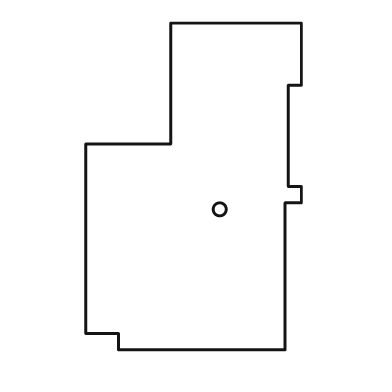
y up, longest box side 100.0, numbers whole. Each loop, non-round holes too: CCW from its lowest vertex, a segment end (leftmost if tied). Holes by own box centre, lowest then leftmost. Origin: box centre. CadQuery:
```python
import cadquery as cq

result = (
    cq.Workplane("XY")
    .moveTo(-23.0, -50.0)
    .lineTo(28.0, -50.0)
    .lineTo(28.0, -5.0)
    .lineTo(33.0, -5.0)
    .lineTo(33.0, 0.0)
    .lineTo(29.0, 0.0)
    .lineTo(29.0, 31.0)
    .lineTo(33.0, 31.0)
    .lineTo(33.0, 50.0)
    .lineTo(-7.0, 50.0)
    .lineTo(-7.0, 13.0)
    .lineTo(-33.0, 13.0)
    .lineTo(-33.0, -45.0)
    .lineTo(-23.0, -45.0)
    .close()
    .moveTo(8.0, -7.0)
    .circle(2.0)
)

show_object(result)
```